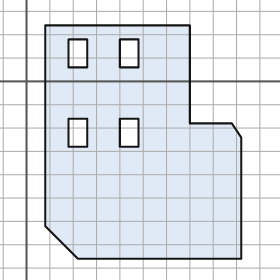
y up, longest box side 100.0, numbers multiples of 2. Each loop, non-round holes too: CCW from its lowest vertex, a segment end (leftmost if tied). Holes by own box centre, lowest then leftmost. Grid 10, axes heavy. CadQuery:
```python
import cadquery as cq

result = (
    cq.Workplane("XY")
    .moveTo(22.0, -76.0)
    .lineTo(92.0, -76.0)
    .lineTo(92.0, -24.0)
    .lineTo(88.0, -18.0)
    .lineTo(70.0, -18.0)
    .lineTo(70.0, 24.0)
    .lineTo(8.0, 24.0)
    .lineTo(8.0, -62.0)
    .close()
    .moveTo(18.0, -28.0)
    .lineTo(26.0, -28.0)
    .lineTo(26.0, -16.0)
    .lineTo(18.0, -16.0)
    .close()
    .moveTo(40.0, -28.0)
    .lineTo(48.0, -28.0)
    .lineTo(48.0, -16.0)
    .lineTo(40.0, -16.0)
    .close()
    .moveTo(18.0, 6.0)
    .lineTo(26.0, 6.0)
    .lineTo(26.0, 18.0)
    .lineTo(18.0, 18.0)
    .close()
    .moveTo(40.0, 6.0)
    .lineTo(48.0, 6.0)
    .lineTo(48.0, 18.0)
    .lineTo(40.0, 18.0)
    .close()
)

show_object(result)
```